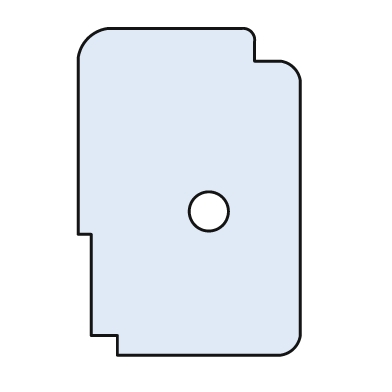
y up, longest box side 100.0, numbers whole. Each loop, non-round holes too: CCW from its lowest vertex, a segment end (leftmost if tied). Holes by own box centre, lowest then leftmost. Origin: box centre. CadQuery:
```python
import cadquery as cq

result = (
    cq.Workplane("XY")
    .moveTo(-22.0, -50.0)
    .lineTo(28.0, -50.0)
    .threePointArc((32.0, -48.0), (34.0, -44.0))
    .lineTo(34.0, 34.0)
    .threePointArc((32.0, 38.0), (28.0, 40.0))
    .lineTo(20.0, 40.0)
    .lineTo(20.0, 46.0)
    .threePointArc((19.0, 49.0), (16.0, 50.0))
    .lineTo(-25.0, 50.0)
    .threePointArc((-31.0, 47.0), (-34.0, 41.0))
    .lineTo(-34.0, -13.0)
    .lineTo(-30.0, -13.0)
    .lineTo(-30.0, -44.0)
    .lineTo(-22.0, -44.0)
    .close()
    .moveTo(6.0, -6.0)
    .circle(6.0)
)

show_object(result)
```